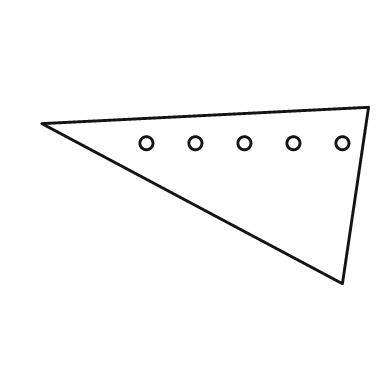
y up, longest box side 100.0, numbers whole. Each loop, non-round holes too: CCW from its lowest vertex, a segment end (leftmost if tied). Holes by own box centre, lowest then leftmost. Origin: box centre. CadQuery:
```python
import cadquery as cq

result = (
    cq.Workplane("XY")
    .moveTo(42.0, -27.0)
    .lineTo(50.0, 27.0)
    .lineTo(-50.0, 22.0)
    .close()
    .moveTo(-18.0, 16.0)
    .circle(2.0)
    .moveTo(-3.0, 16.0)
    .circle(2.0)
    .moveTo(12.0, 16.0)
    .circle(2.0)
    .moveTo(27.0, 16.0)
    .circle(2.0)
    .moveTo(42.0, 16.0)
    .circle(2.0)
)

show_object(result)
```